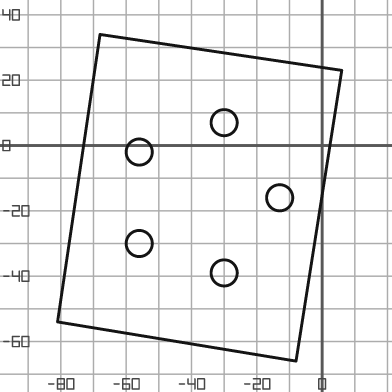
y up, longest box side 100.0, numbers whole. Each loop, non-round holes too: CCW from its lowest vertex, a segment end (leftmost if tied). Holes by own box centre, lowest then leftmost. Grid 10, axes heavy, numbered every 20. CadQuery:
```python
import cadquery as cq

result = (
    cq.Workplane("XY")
    .moveTo(-8.0, -66.0)
    .lineTo(6.0, 23.0)
    .lineTo(-68.0, 34.0)
    .lineTo(-81.0, -54.0)
    .close()
    .moveTo(-30.0, -39.0)
    .circle(4.0)
    .moveTo(-56.0, -30.0)
    .circle(4.0)
    .moveTo(-13.0, -16.0)
    .circle(4.0)
    .moveTo(-56.0, -2.0)
    .circle(4.0)
    .moveTo(-30.0, 7.0)
    .circle(4.0)
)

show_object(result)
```